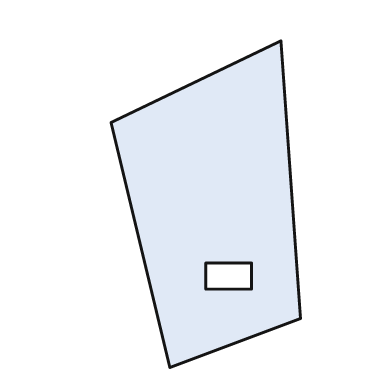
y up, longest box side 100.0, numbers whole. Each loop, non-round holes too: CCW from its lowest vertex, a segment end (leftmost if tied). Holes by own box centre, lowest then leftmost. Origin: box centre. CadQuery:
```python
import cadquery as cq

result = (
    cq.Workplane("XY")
    .moveTo(-11.0, -50.0)
    .lineTo(29.0, -35.0)
    .lineTo(23.0, 50.0)
    .lineTo(-29.0, 25.0)
    .close()
    .moveTo(0.0, -26.0)
    .lineTo(14.0, -26.0)
    .lineTo(14.0, -18.0)
    .lineTo(0.0, -18.0)
    .close()
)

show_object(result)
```